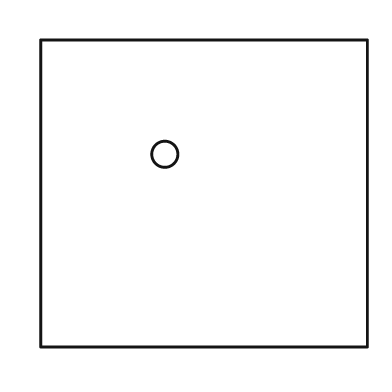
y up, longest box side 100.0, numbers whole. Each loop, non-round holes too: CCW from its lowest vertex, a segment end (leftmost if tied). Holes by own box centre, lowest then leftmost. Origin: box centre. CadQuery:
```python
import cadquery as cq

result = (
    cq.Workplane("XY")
    .moveTo(-50.0, -47.0)
    .lineTo(50.0, -47.0)
    .lineTo(50.0, 47.0)
    .lineTo(-50.0, 47.0)
    .close()
    .moveTo(-12.0, 12.0)
    .circle(4.0)
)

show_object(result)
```